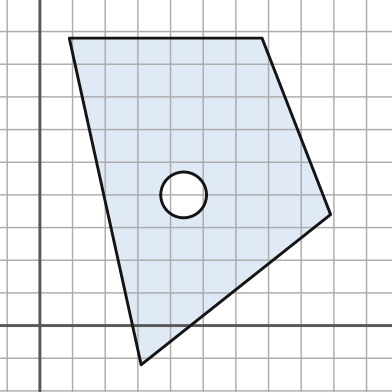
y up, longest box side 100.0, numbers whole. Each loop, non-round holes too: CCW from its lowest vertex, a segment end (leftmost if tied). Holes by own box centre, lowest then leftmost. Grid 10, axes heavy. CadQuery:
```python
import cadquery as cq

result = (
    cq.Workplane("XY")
    .moveTo(31.0, -12.0)
    .lineTo(89.0, 34.0)
    .lineTo(68.0, 88.0)
    .lineTo(9.0, 88.0)
    .close()
    .moveTo(44.0, 40.0)
    .circle(7.0)
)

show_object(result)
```